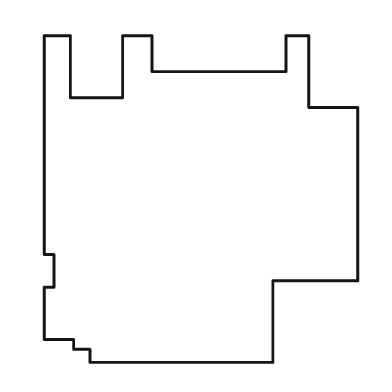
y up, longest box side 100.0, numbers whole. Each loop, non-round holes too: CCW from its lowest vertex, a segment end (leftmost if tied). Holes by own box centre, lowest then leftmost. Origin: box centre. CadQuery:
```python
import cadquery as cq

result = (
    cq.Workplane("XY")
    .moveTo(-34.0, -50.0)
    .lineTo(22.0, -50.0)
    .lineTo(22.0, -25.0)
    .lineTo(48.0, -25.0)
    .lineTo(48.0, 28.0)
    .lineTo(33.0, 28.0)
    .lineTo(33.0, 50.0)
    .lineTo(26.0, 50.0)
    .lineTo(26.0, 39.0)
    .lineTo(-15.0, 39.0)
    .lineTo(-15.0, 50.0)
    .lineTo(-24.0, 50.0)
    .lineTo(-24.0, 31.0)
    .lineTo(-40.0, 31.0)
    .lineTo(-40.0, 50.0)
    .lineTo(-48.0, 50.0)
    .lineTo(-48.0, -17.0)
    .lineTo(-45.0, -17.0)
    .lineTo(-45.0, -27.0)
    .lineTo(-48.0, -27.0)
    .lineTo(-48.0, -43.0)
    .lineTo(-39.0, -43.0)
    .lineTo(-39.0, -46.0)
    .lineTo(-34.0, -46.0)
    .close()
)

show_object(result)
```